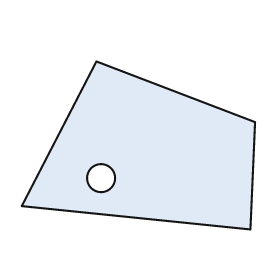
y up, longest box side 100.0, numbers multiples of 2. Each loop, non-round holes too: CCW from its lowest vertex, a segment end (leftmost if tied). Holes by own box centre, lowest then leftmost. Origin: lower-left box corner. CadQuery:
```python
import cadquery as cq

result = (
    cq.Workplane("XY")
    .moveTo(98.0, 0.0)
    .lineTo(100.0, 46.0)
    .lineTo(32.0, 72.0)
    .lineTo(0.0, 10.0)
    .close()
    .moveTo(34.0, 22.0)
    .circle(6.0)
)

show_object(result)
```